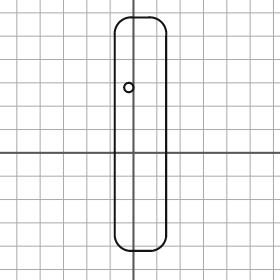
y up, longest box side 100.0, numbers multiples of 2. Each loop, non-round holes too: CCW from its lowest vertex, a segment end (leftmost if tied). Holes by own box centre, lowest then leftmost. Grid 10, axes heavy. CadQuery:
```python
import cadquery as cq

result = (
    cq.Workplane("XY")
    .moveTo(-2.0, -42.0)
    .lineTo(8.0, -42.0)
    .threePointArc((12.0, -40.0), (14.0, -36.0))
    .lineTo(14.0, 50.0)
    .threePointArc((12.0, 56.0), (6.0, 58.0))
    .lineTo(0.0, 58.0)
    .threePointArc((-6.0, 56.0), (-8.0, 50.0))
    .lineTo(-8.0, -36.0)
    .threePointArc((-6.0, -40.0), (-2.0, -42.0))
    .close()
    .moveTo(-2.0, 28.0)
    .circle(2.0)
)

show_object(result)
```